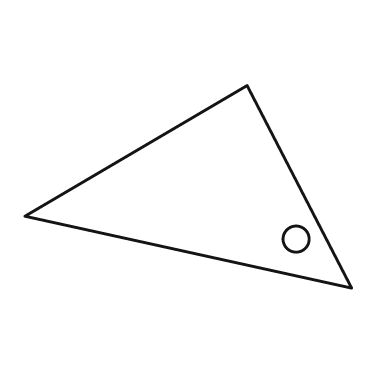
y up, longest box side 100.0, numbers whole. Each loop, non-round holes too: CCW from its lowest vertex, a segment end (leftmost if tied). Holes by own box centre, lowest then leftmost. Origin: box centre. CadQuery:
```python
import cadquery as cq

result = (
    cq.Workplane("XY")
    .moveTo(50.0, -31.0)
    .lineTo(18.0, 31.0)
    .lineTo(-50.0, -9.0)
    .close()
    .moveTo(33.0, -16.0)
    .circle(4.0)
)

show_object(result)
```